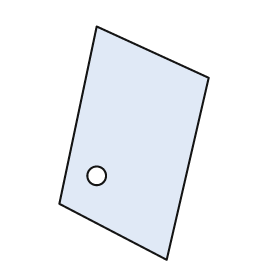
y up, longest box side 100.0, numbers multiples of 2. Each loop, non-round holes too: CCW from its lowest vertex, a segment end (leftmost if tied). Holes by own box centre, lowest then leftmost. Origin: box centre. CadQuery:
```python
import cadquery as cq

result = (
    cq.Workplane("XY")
    .moveTo(14.0, -50.0)
    .lineTo(32.0, 28.0)
    .lineTo(-16.0, 50.0)
    .lineTo(-32.0, -26.0)
    .close()
    .moveTo(-16.0, -14.0)
    .circle(4.0)
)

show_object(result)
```